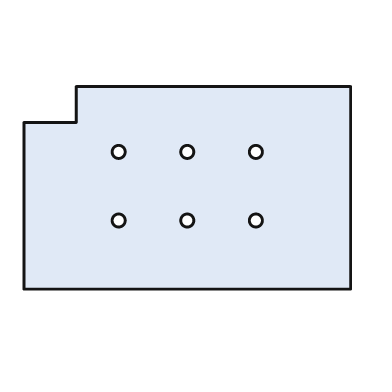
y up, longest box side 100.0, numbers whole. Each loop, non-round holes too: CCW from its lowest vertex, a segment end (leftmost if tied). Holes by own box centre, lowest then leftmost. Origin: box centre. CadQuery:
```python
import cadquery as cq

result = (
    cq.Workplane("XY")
    .moveTo(-50.0, -31.0)
    .lineTo(50.0, -31.0)
    .lineTo(50.0, 31.0)
    .lineTo(-34.0, 31.0)
    .lineTo(-34.0, 20.0)
    .lineTo(-50.0, 20.0)
    .close()
    .moveTo(-21.0, -10.0)
    .circle(2.0)
    .moveTo(0.0, -10.0)
    .circle(2.0)
    .moveTo(21.0, -10.0)
    .circle(2.0)
    .moveTo(-21.0, 11.0)
    .circle(2.0)
    .moveTo(0.0, 11.0)
    .circle(2.0)
    .moveTo(21.0, 11.0)
    .circle(2.0)
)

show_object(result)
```